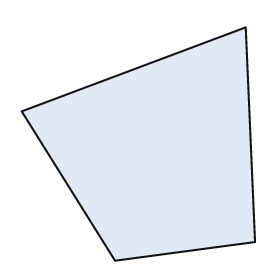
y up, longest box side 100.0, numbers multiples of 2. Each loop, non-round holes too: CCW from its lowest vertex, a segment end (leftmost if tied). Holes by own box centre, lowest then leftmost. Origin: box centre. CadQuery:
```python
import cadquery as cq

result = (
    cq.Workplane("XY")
    .moveTo(-10.0, -50.0)
    .lineTo(50.0, -42.0)
    .lineTo(46.0, 50.0)
    .lineTo(-50.0, 14.0)
    .close()
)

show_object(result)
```